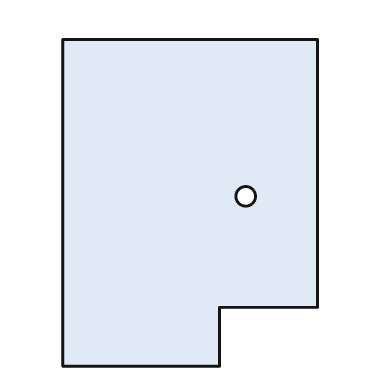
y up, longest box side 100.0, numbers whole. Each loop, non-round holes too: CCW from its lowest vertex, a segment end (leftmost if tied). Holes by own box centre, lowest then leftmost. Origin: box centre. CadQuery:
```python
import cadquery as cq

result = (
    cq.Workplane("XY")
    .moveTo(-39.0, -50.0)
    .lineTo(9.0, -50.0)
    .lineTo(9.0, -32.0)
    .lineTo(39.0, -32.0)
    .lineTo(39.0, 50.0)
    .lineTo(-39.0, 50.0)
    .close()
    .moveTo(17.0, 2.0)
    .circle(3.0)
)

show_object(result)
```